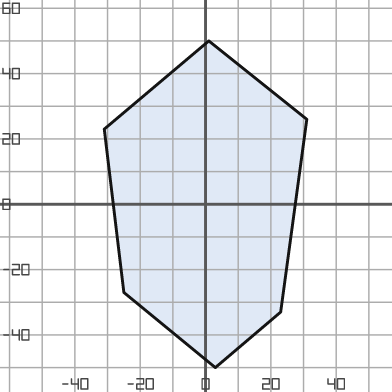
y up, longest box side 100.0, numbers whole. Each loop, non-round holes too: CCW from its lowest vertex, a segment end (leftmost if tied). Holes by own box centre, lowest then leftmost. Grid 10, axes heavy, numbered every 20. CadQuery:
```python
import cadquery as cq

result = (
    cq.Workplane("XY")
    .moveTo(3.0, -50.0)
    .lineTo(23.0, -33.0)
    .lineTo(31.0, 26.0)
    .lineTo(1.0, 50.0)
    .lineTo(-31.0, 23.0)
    .lineTo(-25.0, -27.0)
    .close()
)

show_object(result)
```